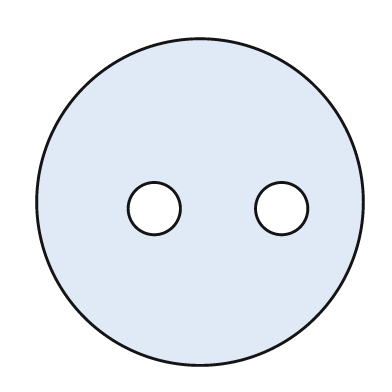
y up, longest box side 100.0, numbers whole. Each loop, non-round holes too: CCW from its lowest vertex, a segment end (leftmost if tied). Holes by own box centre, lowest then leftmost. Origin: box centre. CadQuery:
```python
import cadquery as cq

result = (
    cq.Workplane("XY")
    .moveTo(0.0, 0.0)
    .circle(50.0)
    .moveTo(-14.0, -2.0)
    .circle(8.0)
    .moveTo(25.0, -2.0)
    .circle(8.0)
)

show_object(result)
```